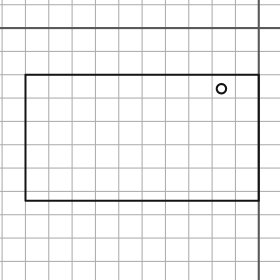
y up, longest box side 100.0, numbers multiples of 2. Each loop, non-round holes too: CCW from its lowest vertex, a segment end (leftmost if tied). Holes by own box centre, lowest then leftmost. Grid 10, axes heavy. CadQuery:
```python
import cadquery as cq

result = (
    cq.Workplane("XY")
    .moveTo(-100.0, -74.0)
    .lineTo(0.0, -74.0)
    .lineTo(0.0, -20.0)
    .lineTo(-100.0, -20.0)
    .close()
    .moveTo(-16.0, -26.0)
    .circle(2.0)
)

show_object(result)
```